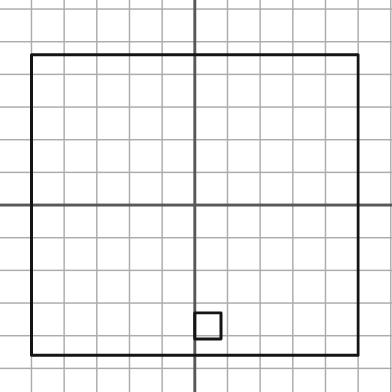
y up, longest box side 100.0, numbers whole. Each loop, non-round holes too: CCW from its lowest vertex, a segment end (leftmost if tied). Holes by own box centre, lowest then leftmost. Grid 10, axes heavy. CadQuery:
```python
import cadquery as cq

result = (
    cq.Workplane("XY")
    .moveTo(-50.0, -46.0)
    .lineTo(50.0, -46.0)
    .lineTo(50.0, 46.0)
    .lineTo(-50.0, 46.0)
    .close()
    .moveTo(0.0, -41.0)
    .lineTo(8.0, -41.0)
    .lineTo(8.0, -33.0)
    .lineTo(0.0, -33.0)
    .close()
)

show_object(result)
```